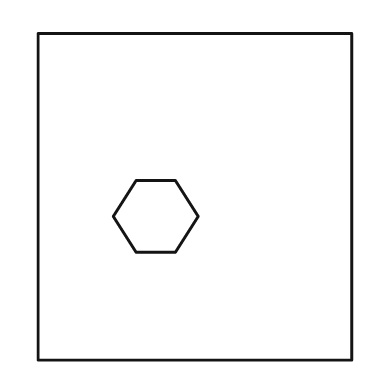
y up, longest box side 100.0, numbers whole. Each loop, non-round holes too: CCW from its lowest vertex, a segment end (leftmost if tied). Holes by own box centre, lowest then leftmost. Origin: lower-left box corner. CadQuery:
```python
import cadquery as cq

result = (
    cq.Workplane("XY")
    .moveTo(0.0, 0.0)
    .lineTo(96.0, 0.0)
    .lineTo(96.0, 100.0)
    .lineTo(0.0, 100.0)
    .close()
    .moveTo(30.0, 33.0)
    .lineTo(42.0, 33.0)
    .lineTo(49.0, 44.0)
    .lineTo(42.0, 55.0)
    .lineTo(30.0, 55.0)
    .lineTo(23.0, 44.0)
    .close()
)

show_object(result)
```